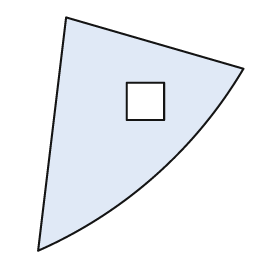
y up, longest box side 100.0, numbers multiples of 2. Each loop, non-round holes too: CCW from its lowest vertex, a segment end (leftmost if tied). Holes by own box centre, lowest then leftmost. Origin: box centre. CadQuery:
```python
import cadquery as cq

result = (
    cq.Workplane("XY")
    .moveTo(-44.0, -50.0)
    .threePointArc((6.0, -18.0), (44.0, 28.0))
    .lineTo(-32.0, 50.0)
    .close()
    .moveTo(-6.0, 6.0)
    .lineTo(10.0, 6.0)
    .lineTo(10.0, 22.0)
    .lineTo(-6.0, 22.0)
    .close()
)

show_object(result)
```